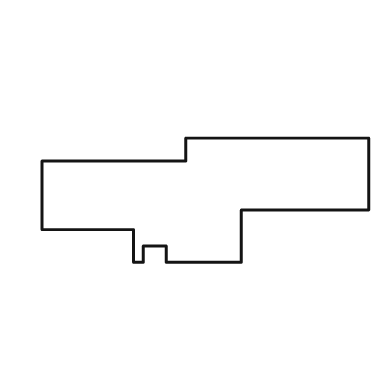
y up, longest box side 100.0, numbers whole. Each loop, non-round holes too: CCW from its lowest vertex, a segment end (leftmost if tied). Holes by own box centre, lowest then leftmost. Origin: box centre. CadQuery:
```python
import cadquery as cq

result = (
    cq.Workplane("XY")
    .moveTo(-22.0, -19.0)
    .lineTo(-19.0, -19.0)
    .lineTo(-19.0, -14.0)
    .lineTo(-12.0, -14.0)
    .lineTo(-12.0, -19.0)
    .lineTo(11.0, -19.0)
    .lineTo(11.0, -3.0)
    .lineTo(50.0, -3.0)
    .lineTo(50.0, 19.0)
    .lineTo(-6.0, 19.0)
    .lineTo(-6.0, 12.0)
    .lineTo(-50.0, 12.0)
    .lineTo(-50.0, -9.0)
    .lineTo(-22.0, -9.0)
    .close()
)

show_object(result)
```